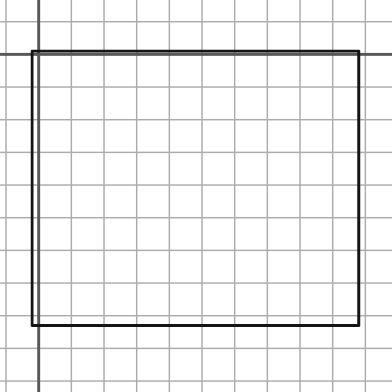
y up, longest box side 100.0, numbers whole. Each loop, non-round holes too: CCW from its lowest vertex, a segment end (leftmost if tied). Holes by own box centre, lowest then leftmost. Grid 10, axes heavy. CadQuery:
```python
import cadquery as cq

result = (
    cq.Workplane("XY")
    .moveTo(-2.0, -83.0)
    .lineTo(98.0, -83.0)
    .lineTo(98.0, 1.0)
    .lineTo(-2.0, 1.0)
    .close()
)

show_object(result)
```